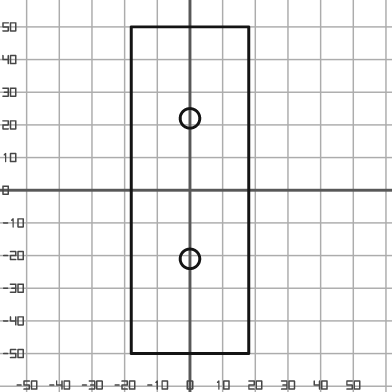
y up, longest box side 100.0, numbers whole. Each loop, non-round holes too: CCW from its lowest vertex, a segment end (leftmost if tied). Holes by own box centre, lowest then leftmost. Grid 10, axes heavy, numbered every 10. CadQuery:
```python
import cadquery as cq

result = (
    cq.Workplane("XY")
    .moveTo(-18.0, -50.0)
    .lineTo(18.0, -50.0)
    .lineTo(18.0, 50.0)
    .lineTo(-18.0, 50.0)
    .close()
    .moveTo(0.0, -21.0)
    .circle(3.0)
    .moveTo(0.0, 22.0)
    .circle(3.0)
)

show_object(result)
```